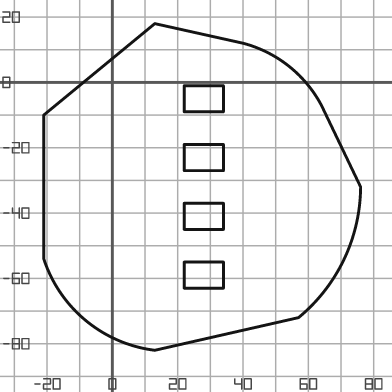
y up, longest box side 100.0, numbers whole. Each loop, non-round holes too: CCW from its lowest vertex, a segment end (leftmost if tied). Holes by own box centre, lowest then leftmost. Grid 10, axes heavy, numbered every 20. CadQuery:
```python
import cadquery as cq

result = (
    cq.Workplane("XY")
    .moveTo(13.0, -82.0)
    .lineTo(57.0, -72.0)
    .threePointArc((71.0, -54.0), (76.0, -32.0))
    .lineTo(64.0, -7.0)
    .threePointArc((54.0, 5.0), (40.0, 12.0))
    .lineTo(13.0, 18.0)
    .lineTo(-21.0, -10.0)
    .lineTo(-21.0, -54.0)
    .threePointArc((-8.0, -73.0), (13.0, -82.0))
    .close()
    .moveTo(22.0, -63.0)
    .lineTo(34.0, -63.0)
    .lineTo(34.0, -55.0)
    .lineTo(22.0, -55.0)
    .close()
    .moveTo(22.0, -45.0)
    .lineTo(34.0, -45.0)
    .lineTo(34.0, -37.0)
    .lineTo(22.0, -37.0)
    .close()
    .moveTo(22.0, -27.0)
    .lineTo(34.0, -27.0)
    .lineTo(34.0, -19.0)
    .lineTo(22.0, -19.0)
    .close()
    .moveTo(22.0, -9.0)
    .lineTo(34.0, -9.0)
    .lineTo(34.0, -1.0)
    .lineTo(22.0, -1.0)
    .close()
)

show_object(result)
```